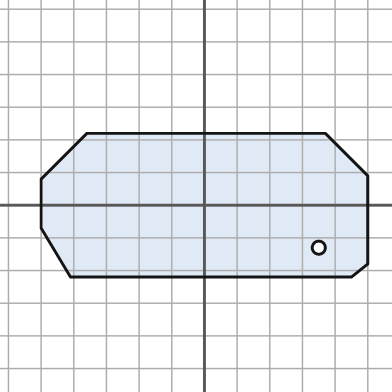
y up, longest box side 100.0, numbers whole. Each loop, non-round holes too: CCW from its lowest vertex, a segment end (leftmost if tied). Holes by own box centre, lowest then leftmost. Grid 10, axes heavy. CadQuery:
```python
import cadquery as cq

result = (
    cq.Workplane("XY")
    .moveTo(-41.0, -22.0)
    .lineTo(45.0, -22.0)
    .lineTo(50.0, -18.0)
    .lineTo(50.0, 9.0)
    .lineTo(37.0, 22.0)
    .lineTo(-36.0, 22.0)
    .lineTo(-50.0, 8.0)
    .lineTo(-50.0, -7.0)
    .close()
    .moveTo(35.0, -13.0)
    .circle(2.0)
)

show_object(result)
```